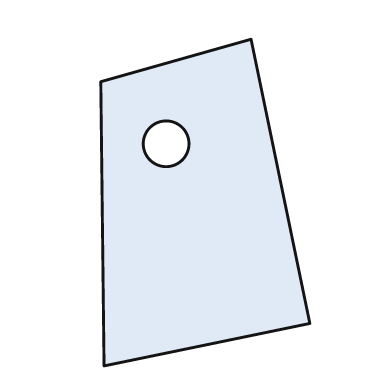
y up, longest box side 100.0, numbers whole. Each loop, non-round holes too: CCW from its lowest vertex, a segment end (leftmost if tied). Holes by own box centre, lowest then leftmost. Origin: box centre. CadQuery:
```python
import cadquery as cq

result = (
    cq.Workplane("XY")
    .moveTo(-31.0, -50.0)
    .lineTo(32.0, -37.0)
    .lineTo(14.0, 50.0)
    .lineTo(-32.0, 37.0)
    .close()
    .moveTo(-12.0, 18.0)
    .circle(7.0)
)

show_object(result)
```